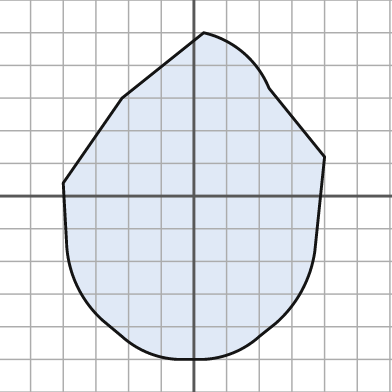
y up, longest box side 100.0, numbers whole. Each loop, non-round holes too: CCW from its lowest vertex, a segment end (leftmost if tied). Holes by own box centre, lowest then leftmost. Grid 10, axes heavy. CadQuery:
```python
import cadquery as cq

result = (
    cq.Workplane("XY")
    .moveTo(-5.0, -50.0)
    .lineTo(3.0, -50.0)
    .threePointArc((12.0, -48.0), (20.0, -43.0))
    .lineTo(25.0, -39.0)
    .threePointArc((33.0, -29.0), (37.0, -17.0))
    .lineTo(40.0, 12.0)
    .lineTo(23.0, 33.0)
    .threePointArc((15.0, 44.0), (3.0, 50.0))
    .lineTo(-22.0, 30.0)
    .lineTo(-40.0, 4.0)
    .lineTo(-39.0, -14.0)
    .threePointArc((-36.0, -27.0), (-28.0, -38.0))
    .lineTo(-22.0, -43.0)
    .threePointArc((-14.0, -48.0), (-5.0, -50.0))
    .close()
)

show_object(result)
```